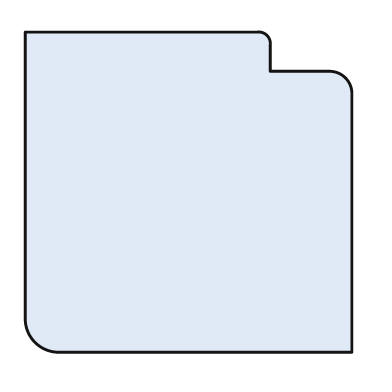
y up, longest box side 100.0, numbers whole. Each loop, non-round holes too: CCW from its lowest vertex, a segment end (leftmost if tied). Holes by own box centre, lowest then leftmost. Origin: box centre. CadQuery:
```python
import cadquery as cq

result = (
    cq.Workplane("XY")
    .moveTo(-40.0, -49.0)
    .lineTo(50.0, -49.0)
    .lineTo(50.0, 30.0)
    .threePointArc((48.0, 35.0), (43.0, 37.0))
    .lineTo(25.0, 37.0)
    .lineTo(25.0, 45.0)
    .threePointArc((24.0, 48.0), (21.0, 49.0))
    .lineTo(-50.0, 49.0)
    .lineTo(-50.0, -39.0)
    .threePointArc((-47.0, -46.0), (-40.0, -49.0))
    .close()
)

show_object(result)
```